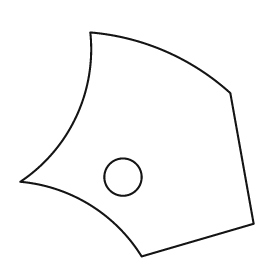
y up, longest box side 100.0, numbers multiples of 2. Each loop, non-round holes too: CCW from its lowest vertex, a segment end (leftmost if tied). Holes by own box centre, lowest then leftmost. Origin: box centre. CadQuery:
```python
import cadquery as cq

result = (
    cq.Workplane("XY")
    .moveTo(2.0, -48.0)
    .lineTo(50.0, -34.0)
    .lineTo(40.0, 22.0)
    .threePointArc((12.0, 40.0), (-20.0, 48.0))
    .threePointArc((-26.0, 12.0), (-50.0, -16.0))
    .threePointArc((-20.0, -26.0), (2.0, -48.0))
    .close()
    .moveTo(-6.0, -14.0)
    .circle(8.0)
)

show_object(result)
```